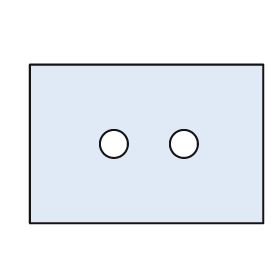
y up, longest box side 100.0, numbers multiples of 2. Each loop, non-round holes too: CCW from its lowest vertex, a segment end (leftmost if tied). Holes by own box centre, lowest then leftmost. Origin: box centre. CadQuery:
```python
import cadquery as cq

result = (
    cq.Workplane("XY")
    .moveTo(-50.0, -34.0)
    .lineTo(50.0, -34.0)
    .lineTo(50.0, 34.0)
    .lineTo(-50.0, 34.0)
    .close()
    .moveTo(-14.0, 0.0)
    .circle(6.0)
    .moveTo(16.0, 0.0)
    .circle(6.0)
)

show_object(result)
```